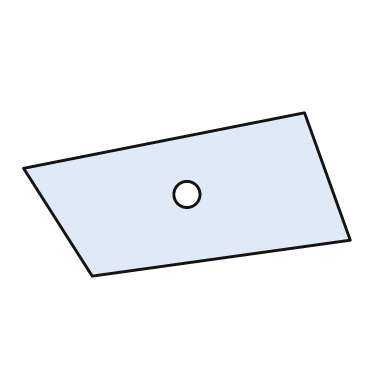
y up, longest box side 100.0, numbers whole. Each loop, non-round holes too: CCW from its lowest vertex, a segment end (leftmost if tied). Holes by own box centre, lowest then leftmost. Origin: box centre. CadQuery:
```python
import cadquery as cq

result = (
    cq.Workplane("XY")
    .moveTo(-29.0, -25.0)
    .lineTo(50.0, -14.0)
    .lineTo(36.0, 25.0)
    .lineTo(-50.0, 8.0)
    .close()
    .moveTo(0.0, 0.0)
    .circle(4.0)
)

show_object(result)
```